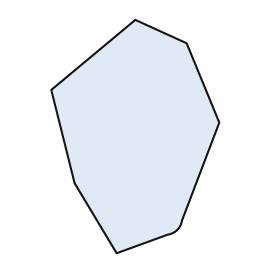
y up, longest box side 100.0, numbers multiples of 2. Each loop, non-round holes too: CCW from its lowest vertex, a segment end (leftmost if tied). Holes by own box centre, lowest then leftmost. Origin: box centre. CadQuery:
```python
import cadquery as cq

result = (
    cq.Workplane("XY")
    .moveTo(-8.0, -50.0)
    .lineTo(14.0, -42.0)
    .threePointArc((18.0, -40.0), (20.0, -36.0))
    .lineTo(36.0, 6.0)
    .lineTo(22.0, 40.0)
    .lineTo(0.0, 50.0)
    .lineTo(-36.0, 20.0)
    .lineTo(-26.0, -20.0)
    .close()
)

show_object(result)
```